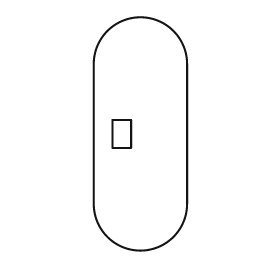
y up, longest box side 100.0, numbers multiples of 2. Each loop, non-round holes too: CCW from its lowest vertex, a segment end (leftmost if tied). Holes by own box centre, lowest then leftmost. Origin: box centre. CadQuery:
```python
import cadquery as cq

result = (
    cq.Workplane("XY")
    .moveTo(-20.0, -30.0)
    .threePointArc((0.0, -50.0), (20.0, -30.0))
    .lineTo(20.0, 30.0)
    .threePointArc((0.0, 50.0), (-20.0, 30.0))
    .close()
    .moveTo(-12.0, -6.0)
    .lineTo(-4.0, -6.0)
    .lineTo(-4.0, 6.0)
    .lineTo(-12.0, 6.0)
    .close()
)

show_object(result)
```